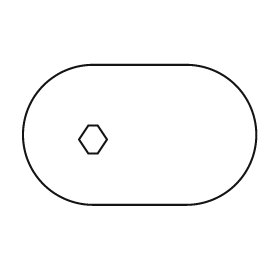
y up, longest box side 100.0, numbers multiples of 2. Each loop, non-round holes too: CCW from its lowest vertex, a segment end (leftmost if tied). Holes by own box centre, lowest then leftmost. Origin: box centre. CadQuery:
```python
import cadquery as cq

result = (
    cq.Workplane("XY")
    .moveTo(-20.0, -30.0)
    .lineTo(20.0, -30.0)
    .threePointArc((50.0, 0.0), (20.0, 30.0))
    .lineTo(-20.0, 30.0)
    .threePointArc((-50.0, 0.0), (-20.0, -30.0))
    .close()
    .moveTo(-22.0, -8.0)
    .lineTo(-18.0, -8.0)
    .lineTo(-14.0, -2.0)
    .lineTo(-18.0, 4.0)
    .lineTo(-22.0, 4.0)
    .lineTo(-26.0, -2.0)
    .close()
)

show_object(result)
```